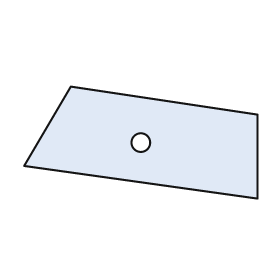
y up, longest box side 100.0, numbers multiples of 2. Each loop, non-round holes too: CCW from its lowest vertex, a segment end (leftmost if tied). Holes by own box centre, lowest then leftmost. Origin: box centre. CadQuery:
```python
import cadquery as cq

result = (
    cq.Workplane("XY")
    .moveTo(50.0, -24.0)
    .lineTo(50.0, 12.0)
    .lineTo(-30.0, 24.0)
    .lineTo(-50.0, -10.0)
    .close()
    .moveTo(0.0, 0.0)
    .circle(4.0)
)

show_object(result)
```